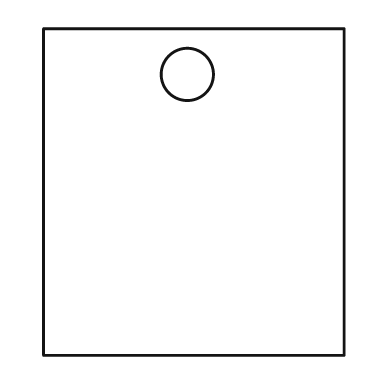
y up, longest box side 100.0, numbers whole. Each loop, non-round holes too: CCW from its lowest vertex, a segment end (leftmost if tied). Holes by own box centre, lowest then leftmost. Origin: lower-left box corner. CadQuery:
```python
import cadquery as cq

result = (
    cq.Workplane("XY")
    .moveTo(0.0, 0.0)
    .lineTo(92.0, 0.0)
    .lineTo(92.0, 100.0)
    .lineTo(0.0, 100.0)
    .close()
    .moveTo(44.0, 86.0)
    .circle(8.0)
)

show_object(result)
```